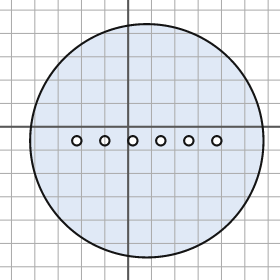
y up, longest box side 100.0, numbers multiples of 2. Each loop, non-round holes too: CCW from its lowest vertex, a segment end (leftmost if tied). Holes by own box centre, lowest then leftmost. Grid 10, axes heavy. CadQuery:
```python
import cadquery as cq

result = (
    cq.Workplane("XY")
    .moveTo(8.0, -6.0)
    .circle(50.0)
    .moveTo(-22.0, -6.0)
    .circle(2.0)
    .moveTo(-10.0, -6.0)
    .circle(2.0)
    .moveTo(2.0, -6.0)
    .circle(2.0)
    .moveTo(14.0, -6.0)
    .circle(2.0)
    .moveTo(26.0, -6.0)
    .circle(2.0)
    .moveTo(38.0, -6.0)
    .circle(2.0)
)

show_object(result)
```